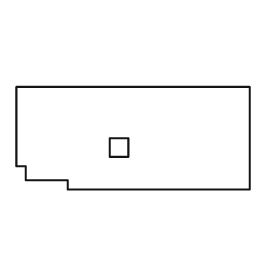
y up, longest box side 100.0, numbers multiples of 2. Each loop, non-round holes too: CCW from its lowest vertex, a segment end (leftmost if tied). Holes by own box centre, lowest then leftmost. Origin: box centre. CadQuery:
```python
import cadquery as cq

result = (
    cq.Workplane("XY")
    .moveTo(-28.0, -22.0)
    .lineTo(50.0, -22.0)
    .lineTo(50.0, 22.0)
    .lineTo(-50.0, 22.0)
    .lineTo(-50.0, -12.0)
    .lineTo(-46.0, -12.0)
    .lineTo(-46.0, -18.0)
    .lineTo(-28.0, -18.0)
    .close()
    .moveTo(-10.0, -8.0)
    .lineTo(-2.0, -8.0)
    .lineTo(-2.0, 0.0)
    .lineTo(-10.0, 0.0)
    .close()
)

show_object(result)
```